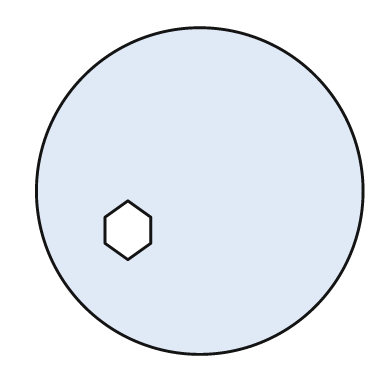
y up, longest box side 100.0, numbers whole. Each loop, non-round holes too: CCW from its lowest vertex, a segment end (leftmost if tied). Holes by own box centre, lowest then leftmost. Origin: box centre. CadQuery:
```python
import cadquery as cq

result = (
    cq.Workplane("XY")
    .moveTo(0.0, 0.0)
    .circle(50.0)
    .moveTo(-22.0, -21.0)
    .lineTo(-15.0, -16.0)
    .lineTo(-15.0, -8.0)
    .lineTo(-22.0, -3.0)
    .lineTo(-29.0, -8.0)
    .lineTo(-29.0, -16.0)
    .close()
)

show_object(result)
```